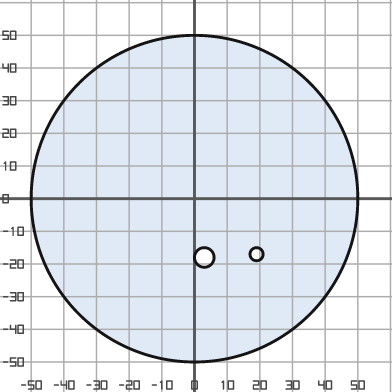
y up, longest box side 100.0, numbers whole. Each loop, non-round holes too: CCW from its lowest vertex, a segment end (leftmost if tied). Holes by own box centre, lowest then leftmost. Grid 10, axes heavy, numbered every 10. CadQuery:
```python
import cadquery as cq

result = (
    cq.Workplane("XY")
    .moveTo(0.0, 0.0)
    .circle(50.0)
    .moveTo(3.0, -18.0)
    .circle(3.0)
    .moveTo(19.0, -17.0)
    .circle(2.0)
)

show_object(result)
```